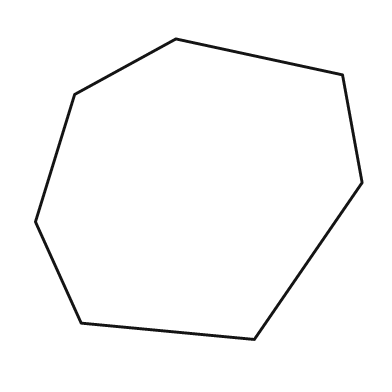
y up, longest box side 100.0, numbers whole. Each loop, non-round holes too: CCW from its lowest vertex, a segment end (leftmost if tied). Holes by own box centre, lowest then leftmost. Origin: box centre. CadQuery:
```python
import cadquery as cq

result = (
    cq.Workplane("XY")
    .moveTo(17.0, -46.0)
    .lineTo(50.0, 2.0)
    .lineTo(44.0, 35.0)
    .lineTo(-7.0, 46.0)
    .lineTo(-38.0, 29.0)
    .lineTo(-50.0, -10.0)
    .lineTo(-36.0, -41.0)
    .close()
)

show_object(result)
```